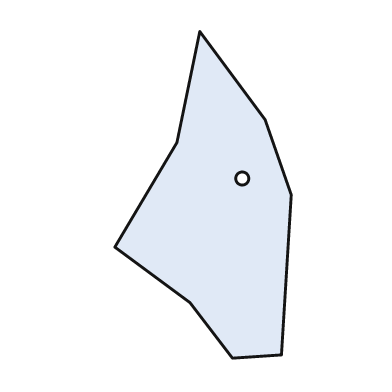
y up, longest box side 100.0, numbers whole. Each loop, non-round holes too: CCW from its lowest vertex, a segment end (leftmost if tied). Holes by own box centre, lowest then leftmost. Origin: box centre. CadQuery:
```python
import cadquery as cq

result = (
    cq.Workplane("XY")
    .moveTo(9.0, -50.0)
    .lineTo(24.0, -49.0)
    .lineTo(27.0, 0.0)
    .lineTo(19.0, 23.0)
    .lineTo(-1.0, 50.0)
    .lineTo(-8.0, 16.0)
    .lineTo(-27.0, -16.0)
    .lineTo(-4.0, -33.0)
    .close()
    .moveTo(12.0, 5.0)
    .circle(2.0)
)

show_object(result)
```